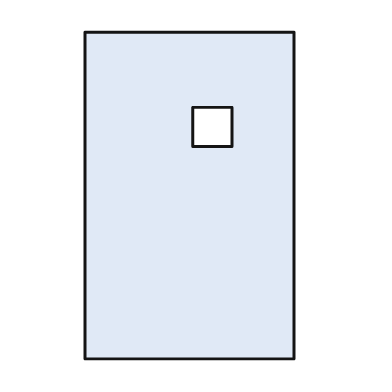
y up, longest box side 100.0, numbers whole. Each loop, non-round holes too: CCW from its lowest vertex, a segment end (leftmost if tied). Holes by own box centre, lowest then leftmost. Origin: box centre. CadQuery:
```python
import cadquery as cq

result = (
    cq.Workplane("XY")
    .moveTo(-32.0, -50.0)
    .lineTo(32.0, -50.0)
    .lineTo(32.0, 50.0)
    .lineTo(-32.0, 50.0)
    .close()
    .moveTo(1.0, 15.0)
    .lineTo(13.0, 15.0)
    .lineTo(13.0, 27.0)
    .lineTo(1.0, 27.0)
    .close()
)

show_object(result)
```